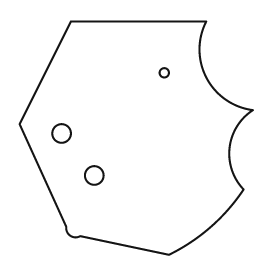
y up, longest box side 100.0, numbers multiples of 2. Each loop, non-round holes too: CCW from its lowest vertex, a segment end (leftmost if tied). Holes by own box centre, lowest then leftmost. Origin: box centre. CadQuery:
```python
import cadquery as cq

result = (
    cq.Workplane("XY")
    .moveTo(14.0, -50.0)
    .threePointArc((32.0, -38.0), (46.0, -22.0))
    .threePointArc((40.0, -4.0), (50.0, 12.0))
    .threePointArc((30.0, 26.0), (30.0, 50.0))
    .lineTo(-28.0, 50.0)
    .lineTo(-50.0, 6.0)
    .lineTo(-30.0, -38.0)
    .threePointArc((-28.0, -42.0), (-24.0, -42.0))
    .close()
    .moveTo(-18.0, -16.0)
    .circle(4.0)
    .moveTo(-32.0, 2.0)
    .circle(4.0)
    .moveTo(12.0, 28.0)
    .circle(2.0)
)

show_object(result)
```